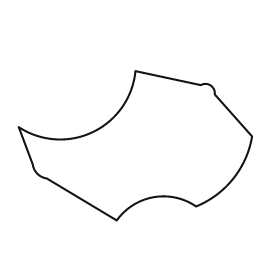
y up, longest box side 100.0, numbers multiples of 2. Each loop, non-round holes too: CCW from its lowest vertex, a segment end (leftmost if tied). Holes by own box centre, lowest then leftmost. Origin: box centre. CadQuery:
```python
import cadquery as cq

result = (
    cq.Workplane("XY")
    .moveTo(-8.0, -32.0)
    .threePointArc((8.0, -22.0), (26.0, -26.0))
    .threePointArc((42.0, -14.0), (50.0, 4.0))
    .lineTo(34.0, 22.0)
    .threePointArc((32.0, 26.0), (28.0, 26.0))
    .lineTo(0.0, 32.0)
    .threePointArc((-18.0, 6.0), (-50.0, 8.0))
    .lineTo(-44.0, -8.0)
    .threePointArc((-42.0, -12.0), (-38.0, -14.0))
    .close()
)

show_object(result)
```